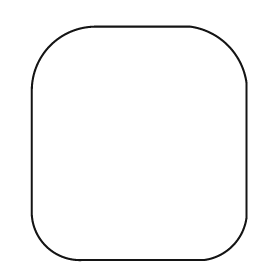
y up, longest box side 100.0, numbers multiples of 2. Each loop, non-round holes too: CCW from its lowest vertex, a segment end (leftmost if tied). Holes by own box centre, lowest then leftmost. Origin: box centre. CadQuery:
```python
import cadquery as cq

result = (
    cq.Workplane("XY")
    .moveTo(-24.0, -50.0)
    .lineTo(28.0, -50.0)
    .threePointArc((40.0, -44.0), (46.0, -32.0))
    .lineTo(46.0, 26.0)
    .threePointArc((38.0, 42.0), (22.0, 50.0))
    .lineTo(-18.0, 50.0)
    .threePointArc((-38.0, 42.0), (-46.0, 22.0))
    .lineTo(-46.0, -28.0)
    .threePointArc((-40.0, -44.0), (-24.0, -50.0))
    .close()
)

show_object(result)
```